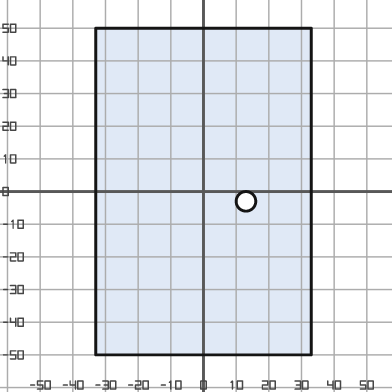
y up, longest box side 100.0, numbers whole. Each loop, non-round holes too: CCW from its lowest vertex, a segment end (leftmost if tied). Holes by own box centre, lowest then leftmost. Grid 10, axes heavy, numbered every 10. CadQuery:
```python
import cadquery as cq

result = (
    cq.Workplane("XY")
    .moveTo(-33.0, -50.0)
    .lineTo(33.0, -50.0)
    .lineTo(33.0, 50.0)
    .lineTo(-33.0, 50.0)
    .close()
    .moveTo(13.0, -3.0)
    .circle(3.0)
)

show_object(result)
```